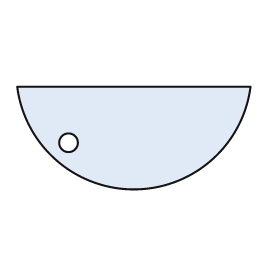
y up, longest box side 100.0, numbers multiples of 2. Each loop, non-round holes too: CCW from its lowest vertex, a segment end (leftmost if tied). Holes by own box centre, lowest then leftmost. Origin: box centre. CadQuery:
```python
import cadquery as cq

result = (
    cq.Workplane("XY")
    .moveTo(-50.0, 22.0)
    .threePointArc((0.0, -22.0), (50.0, 22.0))
    .close()
    .moveTo(-28.0, -2.0)
    .circle(4.0)
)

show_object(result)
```